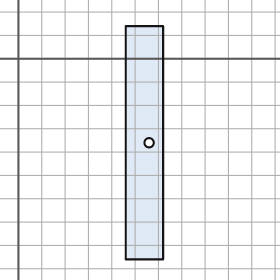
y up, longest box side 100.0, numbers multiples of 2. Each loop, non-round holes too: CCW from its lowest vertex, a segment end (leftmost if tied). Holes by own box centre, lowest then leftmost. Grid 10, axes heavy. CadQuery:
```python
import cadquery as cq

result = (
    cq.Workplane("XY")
    .moveTo(46.0, -86.0)
    .lineTo(62.0, -86.0)
    .lineTo(62.0, 14.0)
    .lineTo(46.0, 14.0)
    .close()
    .moveTo(56.0, -36.0)
    .circle(2.0)
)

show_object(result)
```